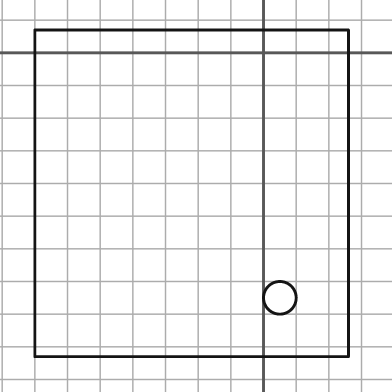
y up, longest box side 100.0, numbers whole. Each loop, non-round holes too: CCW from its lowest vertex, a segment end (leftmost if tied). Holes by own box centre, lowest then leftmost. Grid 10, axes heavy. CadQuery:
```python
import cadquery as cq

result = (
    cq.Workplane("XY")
    .moveTo(-70.0, -93.0)
    .lineTo(26.0, -93.0)
    .lineTo(26.0, 7.0)
    .lineTo(-70.0, 7.0)
    .close()
    .moveTo(5.0, -75.0)
    .circle(5.0)
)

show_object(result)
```